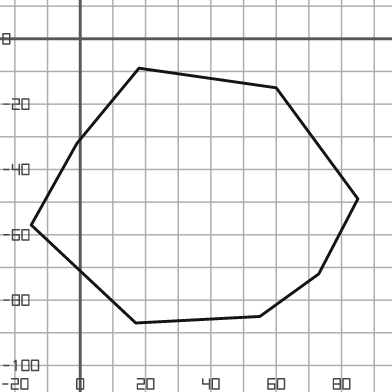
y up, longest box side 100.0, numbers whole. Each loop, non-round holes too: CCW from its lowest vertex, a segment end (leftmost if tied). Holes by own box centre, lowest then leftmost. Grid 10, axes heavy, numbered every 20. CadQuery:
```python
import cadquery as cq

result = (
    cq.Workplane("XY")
    .moveTo(17.0, -87.0)
    .lineTo(55.0, -85.0)
    .lineTo(73.0, -72.0)
    .lineTo(85.0, -49.0)
    .lineTo(60.0, -15.0)
    .lineTo(18.0, -9.0)
    .lineTo(-1.0, -32.0)
    .lineTo(-15.0, -57.0)
    .close()
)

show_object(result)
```